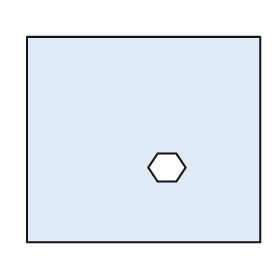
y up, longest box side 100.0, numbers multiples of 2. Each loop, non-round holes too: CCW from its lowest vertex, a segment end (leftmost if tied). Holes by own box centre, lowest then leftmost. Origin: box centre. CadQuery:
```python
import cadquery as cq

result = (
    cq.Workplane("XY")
    .moveTo(-50.0, -44.0)
    .lineTo(50.0, -44.0)
    .lineTo(50.0, 44.0)
    .lineTo(-50.0, 44.0)
    .close()
    .moveTo(6.0, -18.0)
    .lineTo(14.0, -18.0)
    .lineTo(18.0, -12.0)
    .lineTo(14.0, -6.0)
    .lineTo(6.0, -6.0)
    .lineTo(2.0, -12.0)
    .close()
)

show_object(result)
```